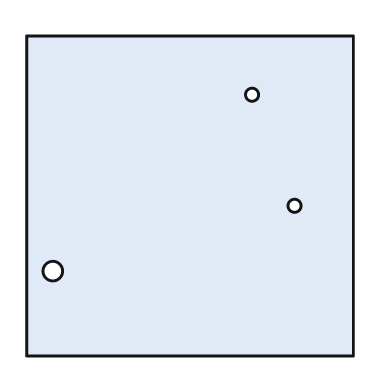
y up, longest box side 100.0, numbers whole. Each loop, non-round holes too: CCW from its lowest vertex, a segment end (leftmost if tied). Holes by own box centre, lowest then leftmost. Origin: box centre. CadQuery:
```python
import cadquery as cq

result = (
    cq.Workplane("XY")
    .moveTo(-50.0, -49.0)
    .lineTo(50.0, -49.0)
    .lineTo(50.0, 49.0)
    .lineTo(-50.0, 49.0)
    .close()
    .moveTo(-42.0, -23.0)
    .circle(3.0)
    .moveTo(32.0, -3.0)
    .circle(2.0)
    .moveTo(19.0, 31.0)
    .circle(2.0)
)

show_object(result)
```